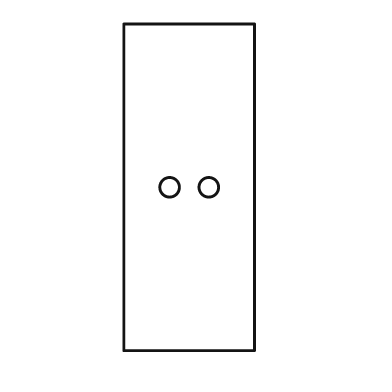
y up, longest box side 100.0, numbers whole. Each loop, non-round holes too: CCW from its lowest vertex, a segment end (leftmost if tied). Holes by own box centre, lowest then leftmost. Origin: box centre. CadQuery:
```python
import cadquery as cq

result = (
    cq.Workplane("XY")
    .moveTo(-20.0, -50.0)
    .lineTo(20.0, -50.0)
    .lineTo(20.0, 50.0)
    .lineTo(-20.0, 50.0)
    .close()
    .moveTo(-6.0, 0.0)
    .circle(3.0)
    .moveTo(6.0, 0.0)
    .circle(3.0)
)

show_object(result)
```